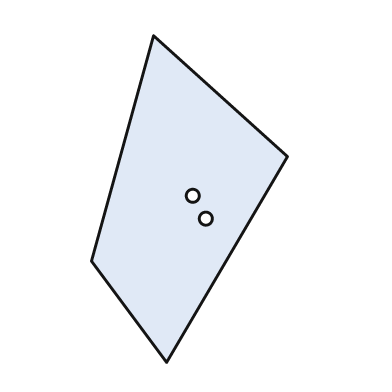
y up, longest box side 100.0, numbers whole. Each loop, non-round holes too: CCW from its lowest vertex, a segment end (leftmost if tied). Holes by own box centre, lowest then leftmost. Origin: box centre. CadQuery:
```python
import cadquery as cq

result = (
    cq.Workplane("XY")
    .moveTo(-7.0, -50.0)
    .lineTo(30.0, 13.0)
    .lineTo(-11.0, 50.0)
    .lineTo(-30.0, -19.0)
    .close()
    .moveTo(5.0, -6.0)
    .circle(2.0)
    .moveTo(1.0, 1.0)
    .circle(2.0)
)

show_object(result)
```